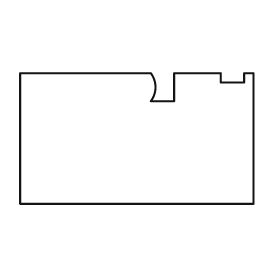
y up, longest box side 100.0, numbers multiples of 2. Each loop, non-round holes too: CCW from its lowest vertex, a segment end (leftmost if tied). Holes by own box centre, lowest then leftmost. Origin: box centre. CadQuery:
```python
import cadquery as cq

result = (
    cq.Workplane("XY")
    .moveTo(-50.0, -28.0)
    .lineTo(50.0, -28.0)
    .lineTo(50.0, 28.0)
    .lineTo(46.0, 28.0)
    .lineTo(46.0, 24.0)
    .lineTo(36.0, 24.0)
    .lineTo(36.0, 28.0)
    .lineTo(16.0, 28.0)
    .lineTo(16.0, 16.0)
    .lineTo(6.0, 16.0)
    .threePointArc((8.0, 22.0), (6.0, 28.0))
    .lineTo(-50.0, 28.0)
    .close()
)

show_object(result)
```